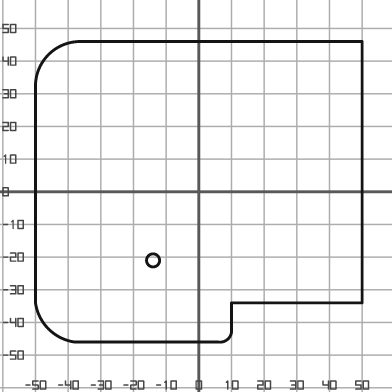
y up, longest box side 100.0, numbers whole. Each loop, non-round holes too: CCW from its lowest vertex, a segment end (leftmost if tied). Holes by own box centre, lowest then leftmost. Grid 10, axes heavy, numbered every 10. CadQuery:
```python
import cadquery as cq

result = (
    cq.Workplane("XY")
    .moveTo(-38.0, -46.0)
    .lineTo(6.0, -46.0)
    .threePointArc((9.0, -45.0), (10.0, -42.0))
    .lineTo(10.0, -34.0)
    .lineTo(50.0, -34.0)
    .lineTo(50.0, 46.0)
    .lineTo(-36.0, 46.0)
    .threePointArc((-46.0, 42.0), (-50.0, 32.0))
    .lineTo(-50.0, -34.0)
    .threePointArc((-46.0, -42.0), (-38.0, -46.0))
    .close()
    .moveTo(-14.0, -21.0)
    .circle(2.0)
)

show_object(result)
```